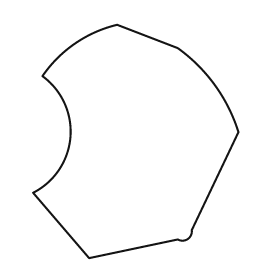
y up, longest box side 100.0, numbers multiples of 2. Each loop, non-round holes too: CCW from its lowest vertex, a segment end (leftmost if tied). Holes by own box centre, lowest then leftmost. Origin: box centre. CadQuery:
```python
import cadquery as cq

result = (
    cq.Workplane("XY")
    .moveTo(-20.0, -50.0)
    .lineTo(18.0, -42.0)
    .threePointArc((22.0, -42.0), (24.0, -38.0))
    .lineTo(44.0, 4.0)
    .threePointArc((34.0, 24.0), (18.0, 40.0))
    .lineTo(-8.0, 50.0)
    .threePointArc((-26.0, 42.0), (-40.0, 28.0))
    .threePointArc((-28.0, 2.0), (-44.0, -22.0))
    .close()
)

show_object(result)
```